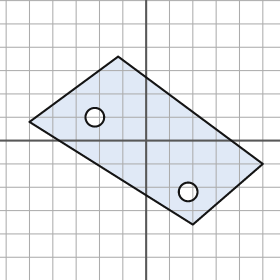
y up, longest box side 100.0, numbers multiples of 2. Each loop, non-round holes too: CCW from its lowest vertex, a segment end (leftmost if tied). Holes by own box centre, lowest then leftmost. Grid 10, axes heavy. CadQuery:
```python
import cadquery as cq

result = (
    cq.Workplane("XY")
    .moveTo(20.0, -36.0)
    .lineTo(50.0, -10.0)
    .lineTo(-12.0, 36.0)
    .lineTo(-50.0, 8.0)
    .close()
    .moveTo(18.0, -22.0)
    .circle(4.0)
    .moveTo(-22.0, 10.0)
    .circle(4.0)
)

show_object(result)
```